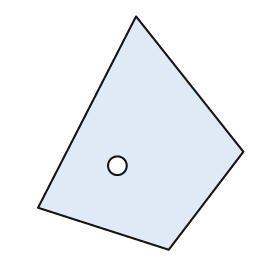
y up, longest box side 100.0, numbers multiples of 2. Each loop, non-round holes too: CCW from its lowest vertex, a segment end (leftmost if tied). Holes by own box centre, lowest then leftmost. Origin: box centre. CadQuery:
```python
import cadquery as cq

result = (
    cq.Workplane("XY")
    .moveTo(12.0, -50.0)
    .lineTo(44.0, -8.0)
    .lineTo(-2.0, 50.0)
    .lineTo(-44.0, -32.0)
    .close()
    .moveTo(-10.0, -14.0)
    .circle(4.0)
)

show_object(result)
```